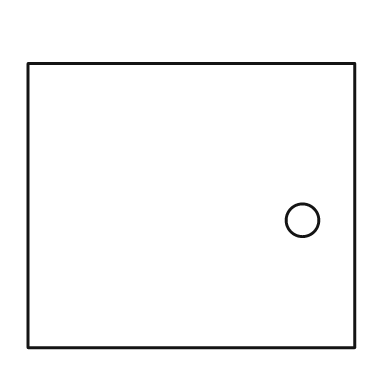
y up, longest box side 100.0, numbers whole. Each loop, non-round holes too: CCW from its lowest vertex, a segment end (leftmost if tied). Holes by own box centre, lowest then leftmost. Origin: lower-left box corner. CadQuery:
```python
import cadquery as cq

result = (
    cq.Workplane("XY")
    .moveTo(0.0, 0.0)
    .lineTo(100.0, 0.0)
    .lineTo(100.0, 87.0)
    .lineTo(0.0, 87.0)
    .close()
    .moveTo(84.0, 39.0)
    .circle(5.0)
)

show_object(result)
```